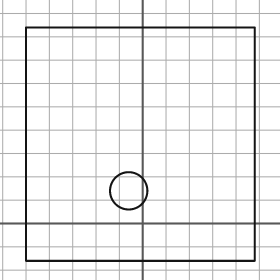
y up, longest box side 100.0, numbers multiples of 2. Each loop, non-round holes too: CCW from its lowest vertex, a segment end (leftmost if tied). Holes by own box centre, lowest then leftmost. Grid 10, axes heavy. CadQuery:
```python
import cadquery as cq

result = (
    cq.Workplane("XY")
    .moveTo(-50.0, -16.0)
    .lineTo(48.0, -16.0)
    .lineTo(48.0, 84.0)
    .lineTo(-50.0, 84.0)
    .close()
    .moveTo(-6.0, 14.0)
    .circle(8.0)
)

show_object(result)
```